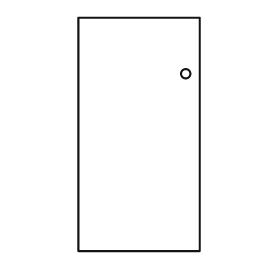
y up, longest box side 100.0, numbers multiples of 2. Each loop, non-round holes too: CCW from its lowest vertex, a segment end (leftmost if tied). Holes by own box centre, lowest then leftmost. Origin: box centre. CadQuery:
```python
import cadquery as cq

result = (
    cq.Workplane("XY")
    .moveTo(-26.0, -50.0)
    .lineTo(26.0, -50.0)
    .lineTo(26.0, 50.0)
    .lineTo(-26.0, 50.0)
    .close()
    .moveTo(20.0, 26.0)
    .circle(2.0)
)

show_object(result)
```